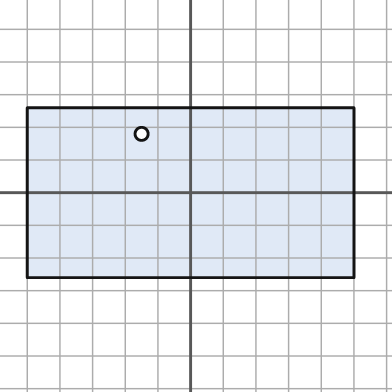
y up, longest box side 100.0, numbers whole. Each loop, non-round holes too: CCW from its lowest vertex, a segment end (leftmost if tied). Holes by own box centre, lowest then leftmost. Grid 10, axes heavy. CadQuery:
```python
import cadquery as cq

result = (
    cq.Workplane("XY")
    .moveTo(-50.0, -26.0)
    .lineTo(50.0, -26.0)
    .lineTo(50.0, 26.0)
    .lineTo(-50.0, 26.0)
    .close()
    .moveTo(-15.0, 18.0)
    .circle(2.0)
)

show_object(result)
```